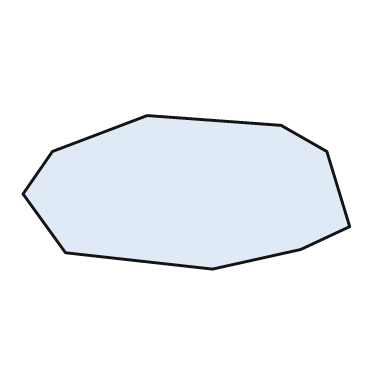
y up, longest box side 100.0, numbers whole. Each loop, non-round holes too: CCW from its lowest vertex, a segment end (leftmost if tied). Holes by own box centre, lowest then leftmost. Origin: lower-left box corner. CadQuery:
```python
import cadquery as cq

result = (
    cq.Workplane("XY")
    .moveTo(58.0, 0.0)
    .lineTo(85.0, 6.0)
    .lineTo(100.0, 13.0)
    .lineTo(93.0, 36.0)
    .lineTo(79.0, 44.0)
    .lineTo(38.0, 47.0)
    .lineTo(9.0, 36.0)
    .lineTo(0.0, 23.0)
    .lineTo(13.0, 5.0)
    .close()
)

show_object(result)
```